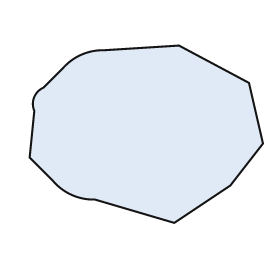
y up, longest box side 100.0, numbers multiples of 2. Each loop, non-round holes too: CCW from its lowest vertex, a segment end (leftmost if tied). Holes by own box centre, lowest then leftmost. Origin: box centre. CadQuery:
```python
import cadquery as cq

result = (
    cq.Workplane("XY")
    .moveTo(12.0, -38.0)
    .lineTo(36.0, -22.0)
    .lineTo(50.0, -4.0)
    .lineTo(44.0, 22.0)
    .lineTo(14.0, 38.0)
    .lineTo(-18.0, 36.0)
    .threePointArc((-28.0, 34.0), (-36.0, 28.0))
    .lineTo(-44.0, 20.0)
    .threePointArc((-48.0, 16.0), (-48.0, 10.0))
    .lineTo(-50.0, -10.0)
    .lineTo(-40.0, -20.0)
    .threePointArc((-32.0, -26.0), (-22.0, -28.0))
    .close()
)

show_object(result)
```